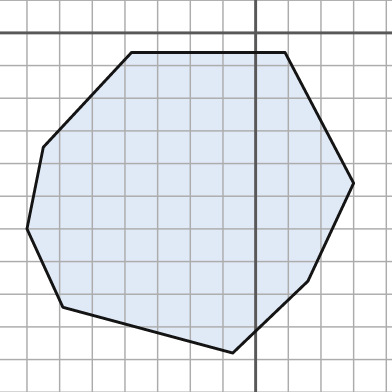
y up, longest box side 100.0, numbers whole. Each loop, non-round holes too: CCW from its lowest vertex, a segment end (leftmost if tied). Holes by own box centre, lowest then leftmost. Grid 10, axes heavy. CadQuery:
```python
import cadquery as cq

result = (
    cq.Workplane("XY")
    .moveTo(-7.0, -98.0)
    .lineTo(16.0, -76.0)
    .lineTo(30.0, -46.0)
    .lineTo(9.0, -6.0)
    .lineTo(-38.0, -6.0)
    .lineTo(-65.0, -35.0)
    .lineTo(-70.0, -60.0)
    .lineTo(-59.0, -84.0)
    .close()
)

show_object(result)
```